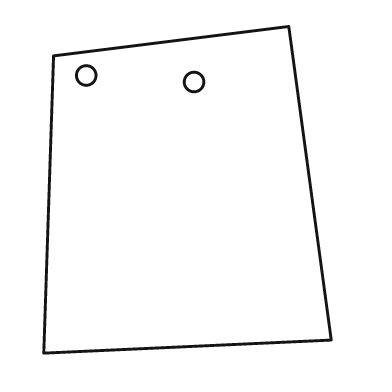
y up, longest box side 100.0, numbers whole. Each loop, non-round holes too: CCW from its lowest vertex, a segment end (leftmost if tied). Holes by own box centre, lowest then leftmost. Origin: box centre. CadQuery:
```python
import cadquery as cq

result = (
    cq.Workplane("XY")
    .moveTo(-44.0, -50.0)
    .lineTo(44.0, -46.0)
    .lineTo(31.0, 50.0)
    .lineTo(-41.0, 41.0)
    .close()
    .moveTo(2.0, 33.0)
    .circle(3.0)
    .moveTo(-31.0, 35.0)
    .circle(3.0)
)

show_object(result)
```